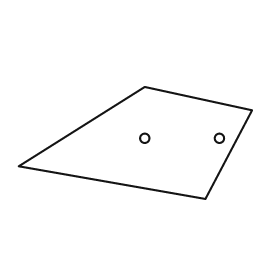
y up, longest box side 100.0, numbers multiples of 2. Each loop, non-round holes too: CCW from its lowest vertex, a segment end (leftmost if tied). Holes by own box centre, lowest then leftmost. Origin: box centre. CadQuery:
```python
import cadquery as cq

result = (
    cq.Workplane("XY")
    .moveTo(30.0, -24.0)
    .lineTo(50.0, 14.0)
    .lineTo(4.0, 24.0)
    .lineTo(-50.0, -10.0)
    .close()
    .moveTo(4.0, 2.0)
    .circle(2.0)
    .moveTo(36.0, 2.0)
    .circle(2.0)
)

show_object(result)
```